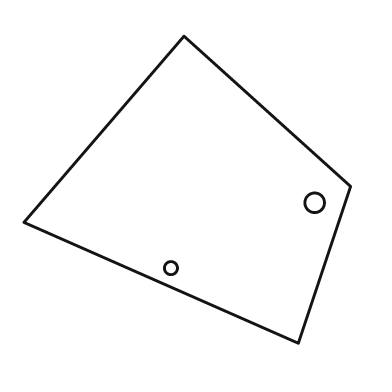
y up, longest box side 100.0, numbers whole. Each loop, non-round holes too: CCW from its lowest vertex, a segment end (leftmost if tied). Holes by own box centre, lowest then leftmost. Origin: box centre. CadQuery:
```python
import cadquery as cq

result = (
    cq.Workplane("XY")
    .moveTo(34.0, -47.0)
    .lineTo(50.0, 1.0)
    .lineTo(-1.0, 47.0)
    .lineTo(-50.0, -10.0)
    .close()
    .moveTo(-5.0, -24.0)
    .circle(2.0)
    .moveTo(39.0, -4.0)
    .circle(3.0)
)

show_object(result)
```